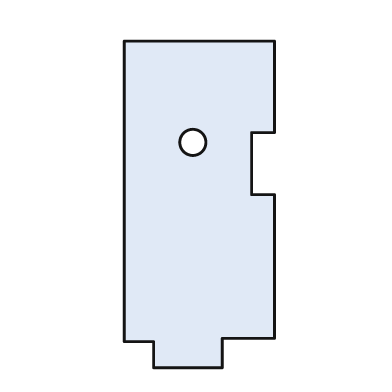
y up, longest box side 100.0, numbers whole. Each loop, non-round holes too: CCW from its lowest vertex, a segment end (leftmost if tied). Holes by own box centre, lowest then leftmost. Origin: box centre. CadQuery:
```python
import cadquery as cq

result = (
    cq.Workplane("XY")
    .moveTo(-14.0, -50.0)
    .lineTo(7.0, -50.0)
    .lineTo(7.0, -41.0)
    .lineTo(23.0, -41.0)
    .lineTo(23.0, 3.0)
    .lineTo(16.0, 3.0)
    .lineTo(16.0, 22.0)
    .lineTo(23.0, 22.0)
    .lineTo(23.0, 50.0)
    .lineTo(-23.0, 50.0)
    .lineTo(-23.0, -42.0)
    .lineTo(-14.0, -42.0)
    .close()
    .moveTo(-2.0, 19.0)
    .circle(4.0)
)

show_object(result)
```